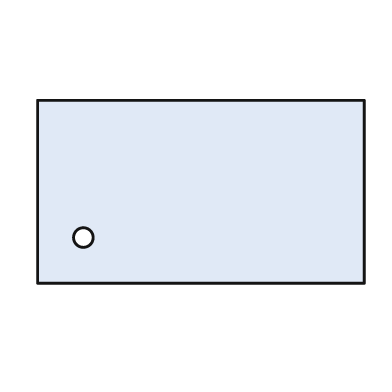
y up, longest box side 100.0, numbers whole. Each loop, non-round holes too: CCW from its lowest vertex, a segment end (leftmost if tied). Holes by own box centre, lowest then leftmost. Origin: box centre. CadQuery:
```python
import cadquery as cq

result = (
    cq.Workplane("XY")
    .moveTo(-50.0, -28.0)
    .lineTo(50.0, -28.0)
    .lineTo(50.0, 28.0)
    .lineTo(-50.0, 28.0)
    .close()
    .moveTo(-36.0, -14.0)
    .circle(3.0)
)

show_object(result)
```